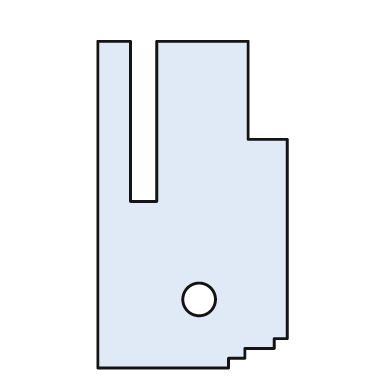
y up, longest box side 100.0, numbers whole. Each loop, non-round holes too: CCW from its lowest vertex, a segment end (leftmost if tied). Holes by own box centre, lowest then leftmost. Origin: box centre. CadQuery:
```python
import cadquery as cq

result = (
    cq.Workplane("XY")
    .moveTo(-29.0, -50.0)
    .lineTo(11.0, -50.0)
    .lineTo(11.0, -47.0)
    .lineTo(16.0, -47.0)
    .lineTo(16.0, -44.0)
    .lineTo(25.0, -44.0)
    .lineTo(25.0, -41.0)
    .lineTo(29.0, -41.0)
    .lineTo(29.0, 20.0)
    .lineTo(17.0, 20.0)
    .lineTo(17.0, 50.0)
    .lineTo(-11.0, 50.0)
    .lineTo(-11.0, 1.0)
    .lineTo(-19.0, 1.0)
    .lineTo(-19.0, 50.0)
    .lineTo(-29.0, 50.0)
    .close()
    .moveTo(2.0, -29.0)
    .circle(5.0)
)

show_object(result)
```